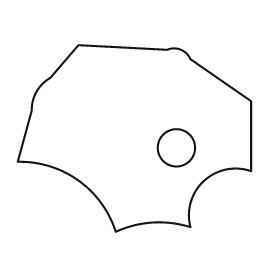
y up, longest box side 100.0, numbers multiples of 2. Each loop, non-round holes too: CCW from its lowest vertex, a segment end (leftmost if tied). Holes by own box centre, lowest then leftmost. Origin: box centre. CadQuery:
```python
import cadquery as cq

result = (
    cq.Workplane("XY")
    .moveTo(-8.0, -40.0)
    .threePointArc((8.0, -36.0), (24.0, -38.0))
    .threePointArc((30.0, -18.0), (50.0, -14.0))
    .lineTo(50.0, 16.0)
    .lineTo(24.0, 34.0)
    .threePointArc((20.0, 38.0), (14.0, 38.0))
    .lineTo(-24.0, 40.0)
    .lineTo(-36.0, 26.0)
    .threePointArc((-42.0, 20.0), (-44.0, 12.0))
    .lineTo(-50.0, -10.0)
    .threePointArc((-24.0, -18.0), (-8.0, -40.0))
    .close()
    .moveTo(18.0, -4.0)
    .circle(8.0)
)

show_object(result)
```